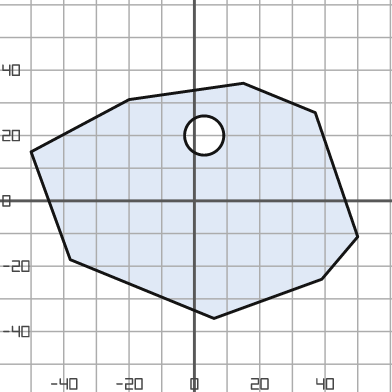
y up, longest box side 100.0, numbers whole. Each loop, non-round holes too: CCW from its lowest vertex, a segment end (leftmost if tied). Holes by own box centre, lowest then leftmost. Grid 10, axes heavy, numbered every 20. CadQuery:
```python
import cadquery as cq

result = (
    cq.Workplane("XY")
    .moveTo(6.0, -36.0)
    .lineTo(39.0, -24.0)
    .lineTo(50.0, -11.0)
    .lineTo(37.0, 27.0)
    .lineTo(15.0, 36.0)
    .lineTo(-20.0, 31.0)
    .lineTo(-50.0, 15.0)
    .lineTo(-38.0, -18.0)
    .close()
    .moveTo(3.0, 20.0)
    .circle(6.0)
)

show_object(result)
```